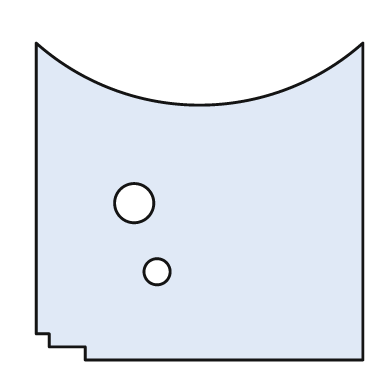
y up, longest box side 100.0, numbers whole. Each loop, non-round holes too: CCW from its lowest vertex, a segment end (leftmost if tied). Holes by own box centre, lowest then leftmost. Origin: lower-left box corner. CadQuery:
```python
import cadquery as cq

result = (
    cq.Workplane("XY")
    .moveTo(15.0, 0.0)
    .lineTo(100.0, 0.0)
    .lineTo(100.0, 97.0)
    .threePointArc((50.0, 78.0), (0.0, 97.0))
    .lineTo(0.0, 8.0)
    .lineTo(4.0, 8.0)
    .lineTo(4.0, 4.0)
    .lineTo(15.0, 4.0)
    .close()
    .moveTo(37.0, 27.0)
    .circle(4.0)
    .moveTo(30.0, 48.0)
    .circle(6.0)
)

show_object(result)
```